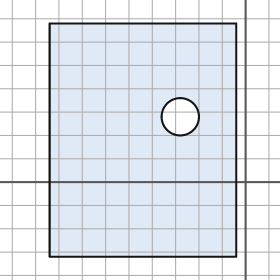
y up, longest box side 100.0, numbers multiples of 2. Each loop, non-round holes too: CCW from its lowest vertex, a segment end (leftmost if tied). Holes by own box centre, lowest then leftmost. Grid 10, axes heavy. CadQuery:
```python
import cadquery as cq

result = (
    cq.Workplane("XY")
    .moveTo(-84.0, -32.0)
    .lineTo(-4.0, -32.0)
    .lineTo(-4.0, 68.0)
    .lineTo(-84.0, 68.0)
    .close()
    .moveTo(-28.0, 28.0)
    .circle(8.0)
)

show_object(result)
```